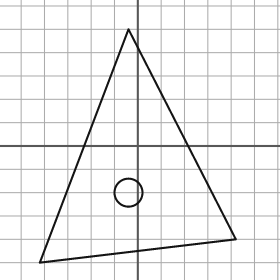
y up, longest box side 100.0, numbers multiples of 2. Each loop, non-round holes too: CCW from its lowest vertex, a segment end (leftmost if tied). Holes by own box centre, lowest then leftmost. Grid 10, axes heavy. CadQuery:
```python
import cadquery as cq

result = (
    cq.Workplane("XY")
    .moveTo(-42.0, -50.0)
    .lineTo(42.0, -40.0)
    .lineTo(-4.0, 50.0)
    .close()
    .moveTo(-4.0, -20.0)
    .circle(6.0)
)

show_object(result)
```